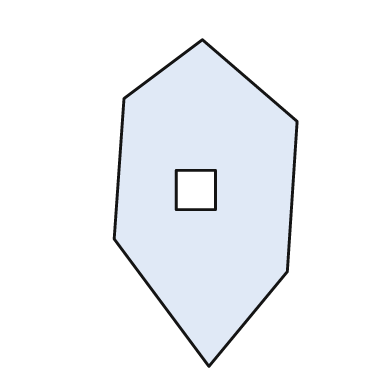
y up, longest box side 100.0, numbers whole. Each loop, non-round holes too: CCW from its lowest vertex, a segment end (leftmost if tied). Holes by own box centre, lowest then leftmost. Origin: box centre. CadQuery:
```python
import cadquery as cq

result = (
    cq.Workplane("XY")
    .moveTo(1.0, -50.0)
    .lineTo(25.0, -21.0)
    .lineTo(28.0, 25.0)
    .lineTo(-1.0, 50.0)
    .lineTo(-25.0, 32.0)
    .lineTo(-28.0, -11.0)
    .close()
    .moveTo(-9.0, -2.0)
    .lineTo(3.0, -2.0)
    .lineTo(3.0, 10.0)
    .lineTo(-9.0, 10.0)
    .close()
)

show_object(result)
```